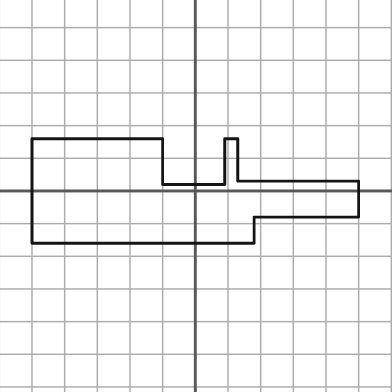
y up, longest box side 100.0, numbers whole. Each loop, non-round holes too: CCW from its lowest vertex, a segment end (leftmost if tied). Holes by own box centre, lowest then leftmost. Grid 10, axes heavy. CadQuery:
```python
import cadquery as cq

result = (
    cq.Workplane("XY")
    .moveTo(-50.0, -16.0)
    .lineTo(18.0, -16.0)
    .lineTo(18.0, -8.0)
    .lineTo(50.0, -8.0)
    .lineTo(50.0, 3.0)
    .lineTo(13.0, 3.0)
    .lineTo(13.0, 16.0)
    .lineTo(9.0, 16.0)
    .lineTo(9.0, 2.0)
    .lineTo(-10.0, 2.0)
    .lineTo(-10.0, 16.0)
    .lineTo(-50.0, 16.0)
    .close()
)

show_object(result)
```